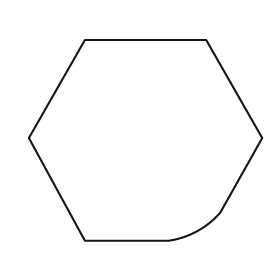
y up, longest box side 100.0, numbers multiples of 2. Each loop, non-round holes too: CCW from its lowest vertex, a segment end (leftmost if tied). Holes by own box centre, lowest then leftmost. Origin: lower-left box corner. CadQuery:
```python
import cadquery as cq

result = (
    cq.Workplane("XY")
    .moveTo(24.0, 0.0)
    .lineTo(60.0, 0.0)
    .threePointArc((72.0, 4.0), (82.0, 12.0))
    .lineTo(100.0, 44.0)
    .lineTo(76.0, 86.0)
    .lineTo(24.0, 86.0)
    .lineTo(0.0, 44.0)
    .close()
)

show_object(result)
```